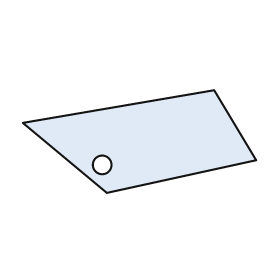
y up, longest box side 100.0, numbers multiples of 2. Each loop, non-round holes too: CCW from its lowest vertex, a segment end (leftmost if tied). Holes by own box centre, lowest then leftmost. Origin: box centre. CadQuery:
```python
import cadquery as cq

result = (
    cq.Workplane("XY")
    .moveTo(-14.0, -22.0)
    .lineTo(50.0, -8.0)
    .lineTo(32.0, 22.0)
    .lineTo(-50.0, 8.0)
    .close()
    .moveTo(-16.0, -10.0)
    .circle(4.0)
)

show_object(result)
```